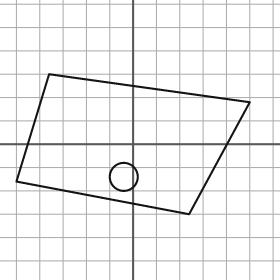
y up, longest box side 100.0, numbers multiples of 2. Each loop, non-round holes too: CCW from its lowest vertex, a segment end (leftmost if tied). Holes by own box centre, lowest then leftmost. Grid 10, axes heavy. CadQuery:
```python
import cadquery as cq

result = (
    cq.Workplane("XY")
    .moveTo(24.0, -30.0)
    .lineTo(50.0, 18.0)
    .lineTo(-36.0, 30.0)
    .lineTo(-50.0, -16.0)
    .close()
    .moveTo(-4.0, -14.0)
    .circle(6.0)
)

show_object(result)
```